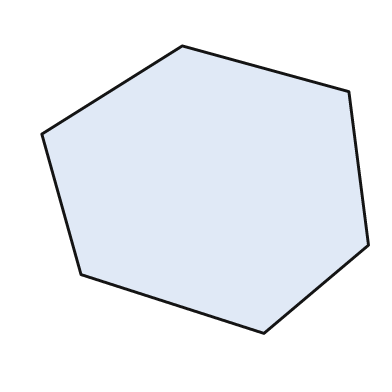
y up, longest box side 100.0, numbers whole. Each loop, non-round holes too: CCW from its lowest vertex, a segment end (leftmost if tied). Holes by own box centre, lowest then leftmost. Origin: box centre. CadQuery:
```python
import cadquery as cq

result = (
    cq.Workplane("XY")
    .moveTo(18.0, -44.0)
    .lineTo(50.0, -17.0)
    .lineTo(44.0, 30.0)
    .lineTo(-7.0, 44.0)
    .lineTo(-50.0, 17.0)
    .lineTo(-38.0, -26.0)
    .close()
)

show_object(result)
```